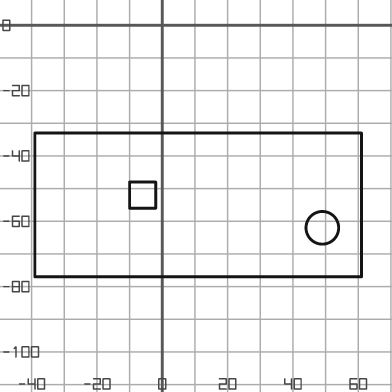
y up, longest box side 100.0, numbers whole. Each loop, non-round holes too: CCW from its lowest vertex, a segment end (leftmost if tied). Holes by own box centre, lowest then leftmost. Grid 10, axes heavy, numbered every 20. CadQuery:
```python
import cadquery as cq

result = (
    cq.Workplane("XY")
    .moveTo(-39.0, -77.0)
    .lineTo(61.0, -77.0)
    .lineTo(61.0, -33.0)
    .lineTo(-39.0, -33.0)
    .close()
    .moveTo(49.0, -62.0)
    .circle(5.0)
    .moveTo(-10.0, -56.0)
    .lineTo(-2.0, -56.0)
    .lineTo(-2.0, -48.0)
    .lineTo(-10.0, -48.0)
    .close()
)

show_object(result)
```